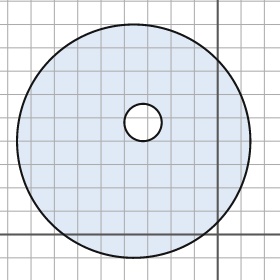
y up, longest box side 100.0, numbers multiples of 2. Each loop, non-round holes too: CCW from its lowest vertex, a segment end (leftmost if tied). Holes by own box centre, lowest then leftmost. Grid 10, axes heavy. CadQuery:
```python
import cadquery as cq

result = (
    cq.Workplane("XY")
    .moveTo(-36.0, 40.0)
    .circle(50.0)
    .moveTo(-32.0, 48.0)
    .circle(8.0)
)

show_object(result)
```